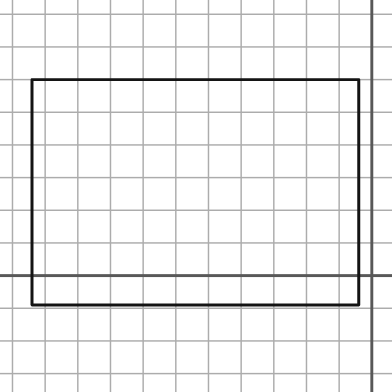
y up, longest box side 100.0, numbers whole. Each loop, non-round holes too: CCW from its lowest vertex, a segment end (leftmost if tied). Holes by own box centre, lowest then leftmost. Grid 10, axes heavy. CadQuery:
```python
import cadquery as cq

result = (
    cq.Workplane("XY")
    .moveTo(-104.0, -9.0)
    .lineTo(-4.0, -9.0)
    .lineTo(-4.0, 60.0)
    .lineTo(-104.0, 60.0)
    .close()
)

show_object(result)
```